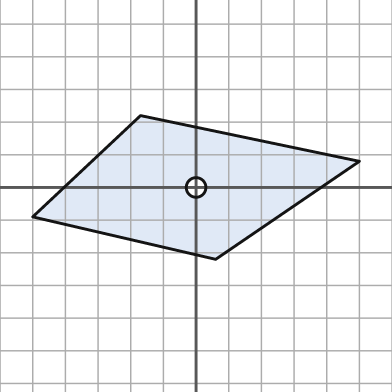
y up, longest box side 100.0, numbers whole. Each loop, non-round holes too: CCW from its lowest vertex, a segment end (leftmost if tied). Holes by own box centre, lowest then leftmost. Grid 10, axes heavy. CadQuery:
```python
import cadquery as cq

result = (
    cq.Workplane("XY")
    .moveTo(6.0, -22.0)
    .lineTo(50.0, 8.0)
    .lineTo(-17.0, 22.0)
    .lineTo(-50.0, -9.0)
    .close()
    .moveTo(0.0, 0.0)
    .circle(3.0)
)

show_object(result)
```